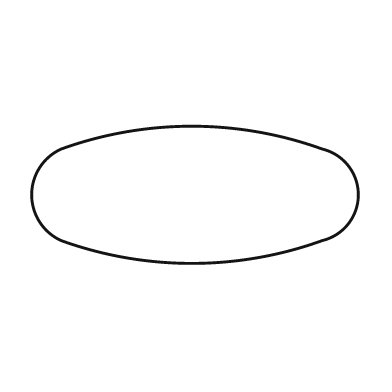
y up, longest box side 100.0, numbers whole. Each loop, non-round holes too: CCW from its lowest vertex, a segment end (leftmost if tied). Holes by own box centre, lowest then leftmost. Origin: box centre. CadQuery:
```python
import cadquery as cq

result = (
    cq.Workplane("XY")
    .moveTo(-41.0, -14.0)
    .threePointArc((-1.0, -21.0), (39.0, -14.0))
    .threePointArc((50.0, 0.0), (39.0, 14.0))
    .threePointArc((-1.0, 21.0), (-41.0, 14.0))
    .threePointArc((-50.0, 0.0), (-41.0, -14.0))
    .close()
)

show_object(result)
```